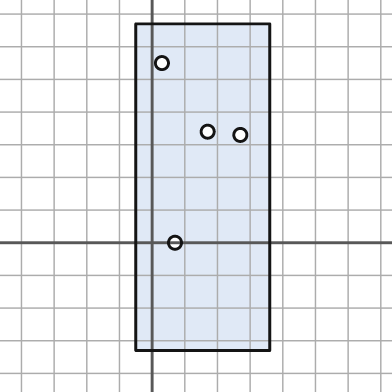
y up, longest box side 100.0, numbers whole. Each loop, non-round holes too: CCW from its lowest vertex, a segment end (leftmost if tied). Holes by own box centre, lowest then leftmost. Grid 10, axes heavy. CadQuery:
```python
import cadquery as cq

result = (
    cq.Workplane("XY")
    .moveTo(-5.0, -33.0)
    .lineTo(36.0, -33.0)
    .lineTo(36.0, 67.0)
    .lineTo(-5.0, 67.0)
    .close()
    .moveTo(7.0, 0.0)
    .circle(2.0)
    .moveTo(27.0, 33.0)
    .circle(2.0)
    .moveTo(17.0, 34.0)
    .circle(2.0)
    .moveTo(3.0, 55.0)
    .circle(2.0)
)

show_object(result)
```